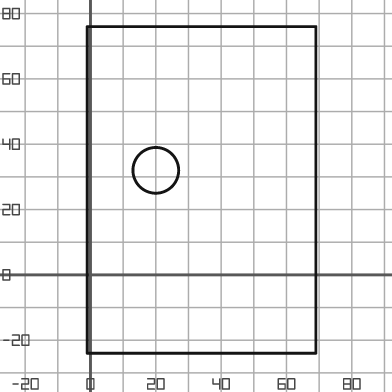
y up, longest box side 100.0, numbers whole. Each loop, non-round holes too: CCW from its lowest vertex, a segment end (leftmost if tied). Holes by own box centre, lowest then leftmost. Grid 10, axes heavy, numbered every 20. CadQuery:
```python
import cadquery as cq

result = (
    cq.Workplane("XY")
    .moveTo(-1.0, -24.0)
    .lineTo(69.0, -24.0)
    .lineTo(69.0, 76.0)
    .lineTo(-1.0, 76.0)
    .close()
    .moveTo(20.0, 32.0)
    .circle(7.0)
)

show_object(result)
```